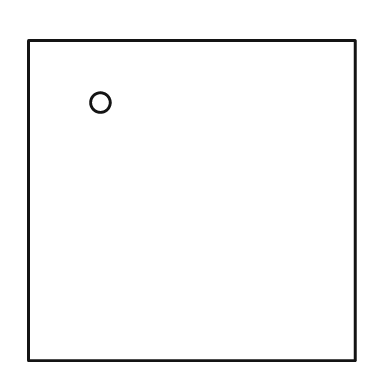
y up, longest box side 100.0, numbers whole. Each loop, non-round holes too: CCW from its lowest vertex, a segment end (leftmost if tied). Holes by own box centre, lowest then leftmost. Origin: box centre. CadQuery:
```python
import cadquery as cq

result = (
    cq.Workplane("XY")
    .moveTo(-50.0, -49.0)
    .lineTo(50.0, -49.0)
    .lineTo(50.0, 49.0)
    .lineTo(-50.0, 49.0)
    .close()
    .moveTo(-28.0, 30.0)
    .circle(3.0)
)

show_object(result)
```